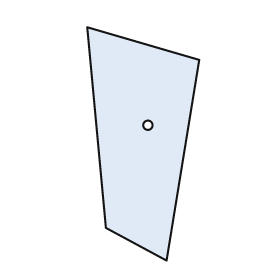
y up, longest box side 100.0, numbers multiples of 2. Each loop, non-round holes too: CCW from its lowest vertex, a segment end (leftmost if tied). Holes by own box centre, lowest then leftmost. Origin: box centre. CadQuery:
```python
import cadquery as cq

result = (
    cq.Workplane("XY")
    .moveTo(10.0, -50.0)
    .lineTo(24.0, 36.0)
    .lineTo(-24.0, 50.0)
    .lineTo(-16.0, -36.0)
    .close()
    .moveTo(2.0, 8.0)
    .circle(2.0)
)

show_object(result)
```